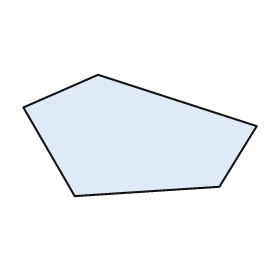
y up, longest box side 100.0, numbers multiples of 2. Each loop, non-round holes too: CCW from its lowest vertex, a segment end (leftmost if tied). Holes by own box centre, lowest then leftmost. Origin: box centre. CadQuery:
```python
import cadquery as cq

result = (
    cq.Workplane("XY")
    .moveTo(-28.0, -26.0)
    .lineTo(34.0, -22.0)
    .lineTo(50.0, 4.0)
    .lineTo(-18.0, 26.0)
    .lineTo(-50.0, 12.0)
    .close()
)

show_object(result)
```